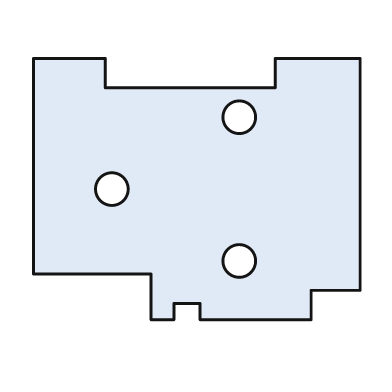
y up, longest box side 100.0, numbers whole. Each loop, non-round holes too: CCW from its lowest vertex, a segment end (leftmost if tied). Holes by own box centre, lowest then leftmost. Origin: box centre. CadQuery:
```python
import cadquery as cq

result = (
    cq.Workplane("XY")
    .moveTo(-14.0, -40.0)
    .lineTo(-7.0, -40.0)
    .lineTo(-7.0, -35.0)
    .lineTo(1.0, -35.0)
    .lineTo(1.0, -40.0)
    .lineTo(35.0, -40.0)
    .lineTo(35.0, -31.0)
    .lineTo(50.0, -31.0)
    .lineTo(50.0, 40.0)
    .lineTo(24.0, 40.0)
    .lineTo(24.0, 31.0)
    .lineTo(-28.0, 31.0)
    .lineTo(-28.0, 40.0)
    .lineTo(-50.0, 40.0)
    .lineTo(-50.0, -26.0)
    .lineTo(-14.0, -26.0)
    .close()
    .moveTo(13.0, -22.0)
    .circle(5.0)
    .moveTo(-26.0, 0.0)
    .circle(5.0)
    .moveTo(13.0, 22.0)
    .circle(5.0)
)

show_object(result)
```